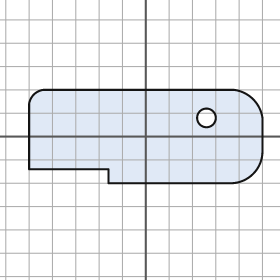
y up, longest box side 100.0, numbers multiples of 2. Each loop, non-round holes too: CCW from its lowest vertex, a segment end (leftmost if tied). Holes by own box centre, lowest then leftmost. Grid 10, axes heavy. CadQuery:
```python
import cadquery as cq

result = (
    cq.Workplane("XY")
    .moveTo(-16.0, -20.0)
    .lineTo(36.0, -20.0)
    .threePointArc((46.0, -16.0), (50.0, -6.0))
    .lineTo(50.0, 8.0)
    .threePointArc((46.0, 16.0), (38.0, 20.0))
    .lineTo(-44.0, 20.0)
    .threePointArc((-48.0, 18.0), (-50.0, 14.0))
    .lineTo(-50.0, -14.0)
    .lineTo(-16.0, -14.0)
    .close()
    .moveTo(26.0, 8.0)
    .circle(4.0)
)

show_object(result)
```